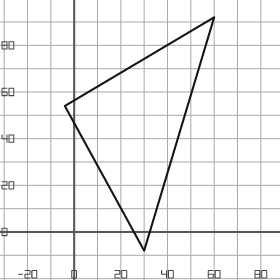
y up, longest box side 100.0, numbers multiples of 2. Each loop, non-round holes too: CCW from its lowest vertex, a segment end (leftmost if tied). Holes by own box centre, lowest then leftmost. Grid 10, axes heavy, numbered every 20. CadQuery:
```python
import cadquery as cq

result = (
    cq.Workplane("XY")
    .moveTo(30.0, -8.0)
    .lineTo(60.0, 92.0)
    .lineTo(-4.0, 54.0)
    .close()
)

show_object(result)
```